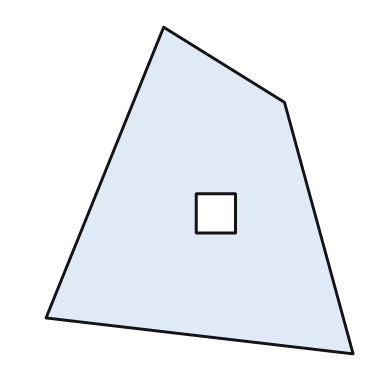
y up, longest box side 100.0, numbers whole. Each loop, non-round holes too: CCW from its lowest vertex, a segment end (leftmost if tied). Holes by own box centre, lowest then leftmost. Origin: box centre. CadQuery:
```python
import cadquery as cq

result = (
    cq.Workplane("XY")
    .moveTo(47.0, -50.0)
    .lineTo(26.0, 27.0)
    .lineTo(-11.0, 50.0)
    .lineTo(-47.0, -39.0)
    .close()
    .moveTo(-1.0, -13.0)
    .lineTo(11.0, -13.0)
    .lineTo(11.0, -1.0)
    .lineTo(-1.0, -1.0)
    .close()
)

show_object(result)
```